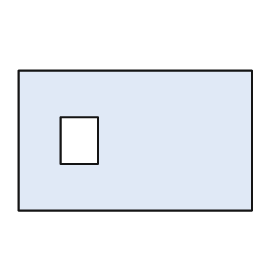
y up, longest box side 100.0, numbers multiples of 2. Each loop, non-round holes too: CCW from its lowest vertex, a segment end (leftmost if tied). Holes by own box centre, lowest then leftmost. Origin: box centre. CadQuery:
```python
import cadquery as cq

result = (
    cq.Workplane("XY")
    .moveTo(-50.0, -30.0)
    .lineTo(50.0, -30.0)
    .lineTo(50.0, 30.0)
    .lineTo(-50.0, 30.0)
    .close()
    .moveTo(-32.0, -10.0)
    .lineTo(-16.0, -10.0)
    .lineTo(-16.0, 10.0)
    .lineTo(-32.0, 10.0)
    .close()
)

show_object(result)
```